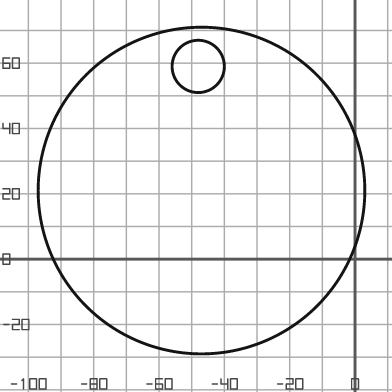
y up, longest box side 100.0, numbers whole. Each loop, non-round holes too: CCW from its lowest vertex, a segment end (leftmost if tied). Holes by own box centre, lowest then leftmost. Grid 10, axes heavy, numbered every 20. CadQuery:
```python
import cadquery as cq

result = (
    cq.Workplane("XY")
    .moveTo(-47.0, 21.0)
    .circle(50.0)
    .moveTo(-48.0, 59.0)
    .circle(8.0)
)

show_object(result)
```